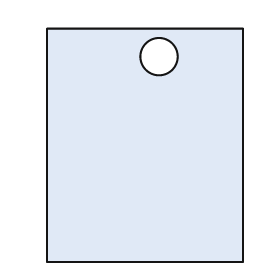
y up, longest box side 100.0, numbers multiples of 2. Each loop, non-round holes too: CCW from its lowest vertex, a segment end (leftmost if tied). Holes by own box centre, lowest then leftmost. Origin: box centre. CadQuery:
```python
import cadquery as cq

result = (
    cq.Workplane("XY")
    .moveTo(-42.0, -50.0)
    .lineTo(42.0, -50.0)
    .lineTo(42.0, 50.0)
    .lineTo(-42.0, 50.0)
    .close()
    .moveTo(6.0, 38.0)
    .circle(8.0)
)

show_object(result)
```